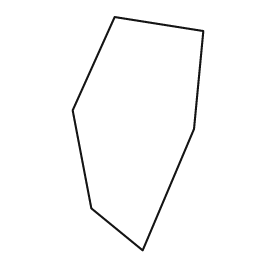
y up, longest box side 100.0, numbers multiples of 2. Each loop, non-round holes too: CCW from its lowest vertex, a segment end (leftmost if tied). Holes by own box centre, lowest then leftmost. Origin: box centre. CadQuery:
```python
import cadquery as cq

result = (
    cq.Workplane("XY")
    .moveTo(2.0, -50.0)
    .lineTo(24.0, 2.0)
    .lineTo(28.0, 44.0)
    .lineTo(-10.0, 50.0)
    .lineTo(-28.0, 10.0)
    .lineTo(-20.0, -32.0)
    .close()
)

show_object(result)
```